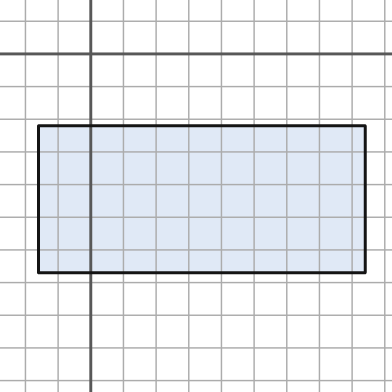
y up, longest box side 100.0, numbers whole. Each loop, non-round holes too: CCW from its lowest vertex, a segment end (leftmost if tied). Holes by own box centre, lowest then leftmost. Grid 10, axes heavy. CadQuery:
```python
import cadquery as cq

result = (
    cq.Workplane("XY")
    .moveTo(-16.0, -67.0)
    .lineTo(84.0, -67.0)
    .lineTo(84.0, -22.0)
    .lineTo(-16.0, -22.0)
    .close()
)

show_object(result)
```